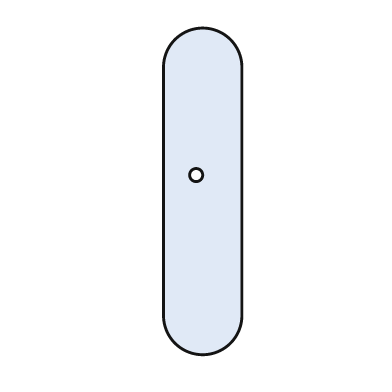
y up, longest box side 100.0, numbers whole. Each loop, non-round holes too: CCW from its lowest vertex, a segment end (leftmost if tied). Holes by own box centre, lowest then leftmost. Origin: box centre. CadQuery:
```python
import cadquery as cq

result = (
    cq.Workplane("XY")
    .moveTo(-12.0, -38.0)
    .threePointArc((0.0, -50.0), (12.0, -38.0))
    .lineTo(12.0, 38.0)
    .threePointArc((0.0, 50.0), (-12.0, 38.0))
    .close()
    .moveTo(-2.0, 5.0)
    .circle(2.0)
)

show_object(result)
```